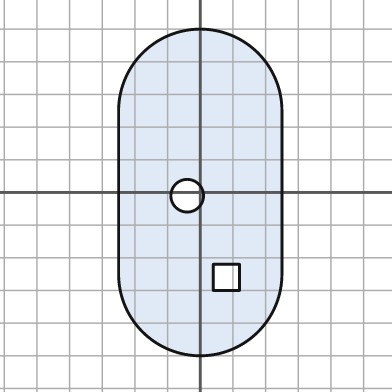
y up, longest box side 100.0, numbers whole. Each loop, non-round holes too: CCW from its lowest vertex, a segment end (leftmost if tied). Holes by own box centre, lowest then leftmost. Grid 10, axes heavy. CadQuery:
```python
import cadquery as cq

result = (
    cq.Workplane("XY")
    .moveTo(-25.0, -25.0)
    .threePointArc((0.0, -50.0), (25.0, -25.0))
    .lineTo(25.0, 25.0)
    .threePointArc((0.0, 50.0), (-25.0, 25.0))
    .close()
    .moveTo(4.0, -30.0)
    .lineTo(12.0, -30.0)
    .lineTo(12.0, -22.0)
    .lineTo(4.0, -22.0)
    .close()
    .moveTo(-4.0, -1.0)
    .circle(5.0)
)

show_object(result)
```